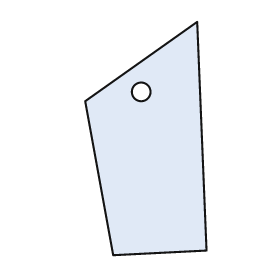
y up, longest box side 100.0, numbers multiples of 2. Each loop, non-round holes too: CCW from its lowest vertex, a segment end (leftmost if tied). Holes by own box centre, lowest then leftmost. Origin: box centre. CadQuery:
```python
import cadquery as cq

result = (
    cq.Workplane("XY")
    .moveTo(-14.0, -50.0)
    .lineTo(26.0, -48.0)
    .lineTo(22.0, 50.0)
    .lineTo(-26.0, 16.0)
    .close()
    .moveTo(-2.0, 20.0)
    .circle(4.0)
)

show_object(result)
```